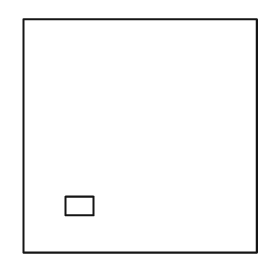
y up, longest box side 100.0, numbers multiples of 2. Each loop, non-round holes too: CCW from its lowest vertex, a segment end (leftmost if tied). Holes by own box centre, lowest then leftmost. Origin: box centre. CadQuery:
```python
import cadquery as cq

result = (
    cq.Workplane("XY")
    .moveTo(-50.0, -50.0)
    .lineTo(50.0, -50.0)
    .lineTo(50.0, 50.0)
    .lineTo(-50.0, 50.0)
    .close()
    .moveTo(-32.0, -34.0)
    .lineTo(-20.0, -34.0)
    .lineTo(-20.0, -26.0)
    .lineTo(-32.0, -26.0)
    .close()
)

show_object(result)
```